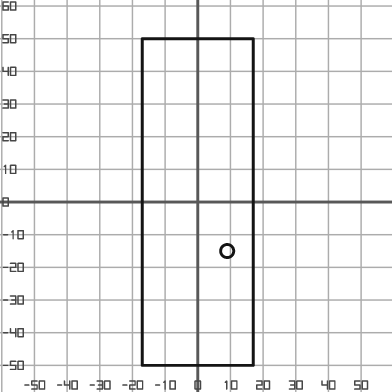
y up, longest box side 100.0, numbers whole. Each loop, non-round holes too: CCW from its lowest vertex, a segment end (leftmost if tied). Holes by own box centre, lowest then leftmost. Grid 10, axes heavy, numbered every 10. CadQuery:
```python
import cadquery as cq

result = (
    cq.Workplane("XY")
    .moveTo(-17.0, -50.0)
    .lineTo(17.0, -50.0)
    .lineTo(17.0, 50.0)
    .lineTo(-17.0, 50.0)
    .close()
    .moveTo(9.0, -15.0)
    .circle(2.0)
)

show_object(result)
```